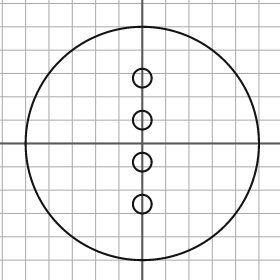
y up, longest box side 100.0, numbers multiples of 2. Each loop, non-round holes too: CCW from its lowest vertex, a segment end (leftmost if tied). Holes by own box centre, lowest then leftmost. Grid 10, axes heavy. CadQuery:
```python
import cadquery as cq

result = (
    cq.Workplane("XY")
    .moveTo(0.0, 0.0)
    .circle(50.0)
    .moveTo(0.0, -26.0)
    .circle(4.0)
    .moveTo(0.0, -8.0)
    .circle(4.0)
    .moveTo(0.0, 10.0)
    .circle(4.0)
    .moveTo(0.0, 28.0)
    .circle(4.0)
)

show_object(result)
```